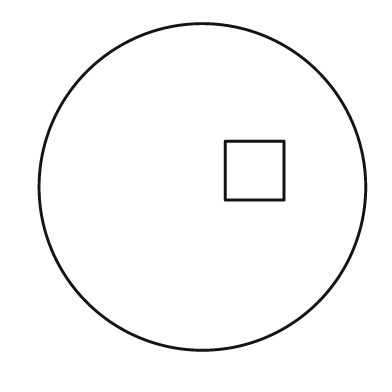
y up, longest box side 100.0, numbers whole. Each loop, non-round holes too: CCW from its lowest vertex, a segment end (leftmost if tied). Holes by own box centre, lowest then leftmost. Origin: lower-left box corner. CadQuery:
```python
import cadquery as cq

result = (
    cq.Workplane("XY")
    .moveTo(50.0, 50.0)
    .circle(50.0)
    .moveTo(57.0, 46.0)
    .lineTo(75.0, 46.0)
    .lineTo(75.0, 64.0)
    .lineTo(57.0, 64.0)
    .close()
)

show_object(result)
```